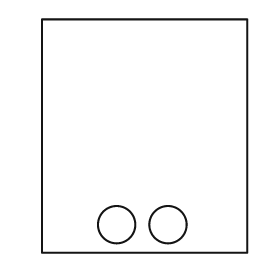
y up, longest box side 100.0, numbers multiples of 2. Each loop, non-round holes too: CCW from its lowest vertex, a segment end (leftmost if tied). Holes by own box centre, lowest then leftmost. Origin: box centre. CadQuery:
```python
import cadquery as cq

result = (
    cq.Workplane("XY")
    .moveTo(-44.0, -50.0)
    .lineTo(44.0, -50.0)
    .lineTo(44.0, 50.0)
    .lineTo(-44.0, 50.0)
    .close()
    .moveTo(-12.0, -38.0)
    .circle(8.0)
    .moveTo(10.0, -38.0)
    .circle(8.0)
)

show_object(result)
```